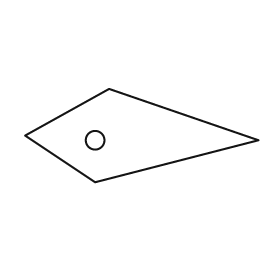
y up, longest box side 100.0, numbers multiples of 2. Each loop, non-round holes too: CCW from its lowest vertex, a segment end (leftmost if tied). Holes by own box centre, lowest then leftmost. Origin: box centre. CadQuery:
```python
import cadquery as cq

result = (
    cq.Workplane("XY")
    .moveTo(-20.0, -20.0)
    .lineTo(50.0, -2.0)
    .lineTo(-14.0, 20.0)
    .lineTo(-50.0, 0.0)
    .close()
    .moveTo(-20.0, -2.0)
    .circle(4.0)
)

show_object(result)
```